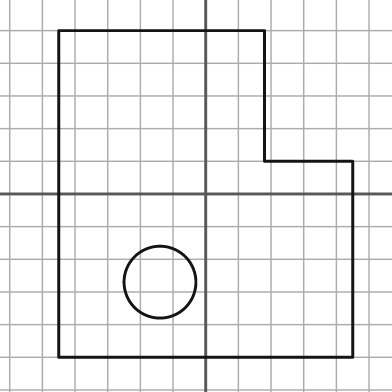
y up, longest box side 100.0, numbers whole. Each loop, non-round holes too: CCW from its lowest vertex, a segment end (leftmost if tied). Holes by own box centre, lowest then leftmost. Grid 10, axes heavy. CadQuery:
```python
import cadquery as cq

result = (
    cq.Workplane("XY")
    .moveTo(-45.0, -50.0)
    .lineTo(45.0, -50.0)
    .lineTo(45.0, 10.0)
    .lineTo(18.0, 10.0)
    .lineTo(18.0, 50.0)
    .lineTo(-45.0, 50.0)
    .close()
    .moveTo(-14.0, -27.0)
    .circle(11.0)
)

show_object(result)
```